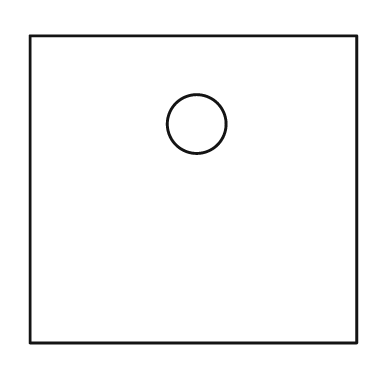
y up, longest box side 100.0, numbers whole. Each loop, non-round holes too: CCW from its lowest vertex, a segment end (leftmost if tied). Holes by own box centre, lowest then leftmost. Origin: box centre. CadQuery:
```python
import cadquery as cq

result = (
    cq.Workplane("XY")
    .moveTo(-50.0, -47.0)
    .lineTo(50.0, -47.0)
    .lineTo(50.0, 47.0)
    .lineTo(-50.0, 47.0)
    .close()
    .moveTo(1.0, 20.0)
    .circle(9.0)
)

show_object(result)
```